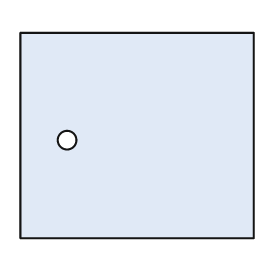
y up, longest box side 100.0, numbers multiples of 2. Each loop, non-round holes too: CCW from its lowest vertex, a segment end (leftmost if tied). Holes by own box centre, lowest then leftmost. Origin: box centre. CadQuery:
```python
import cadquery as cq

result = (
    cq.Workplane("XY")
    .moveTo(-50.0, -44.0)
    .lineTo(50.0, -44.0)
    .lineTo(50.0, 44.0)
    .lineTo(-50.0, 44.0)
    .close()
    .moveTo(-30.0, -2.0)
    .circle(4.0)
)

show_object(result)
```